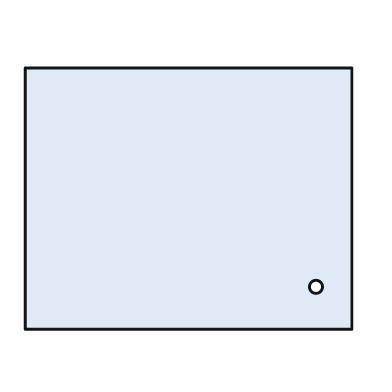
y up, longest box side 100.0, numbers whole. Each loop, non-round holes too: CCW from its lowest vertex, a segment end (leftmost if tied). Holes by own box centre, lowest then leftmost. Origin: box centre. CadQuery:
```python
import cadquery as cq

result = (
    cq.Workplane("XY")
    .moveTo(-50.0, -40.0)
    .lineTo(50.0, -40.0)
    .lineTo(50.0, 40.0)
    .lineTo(-50.0, 40.0)
    .close()
    .moveTo(39.0, -27.0)
    .circle(2.0)
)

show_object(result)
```